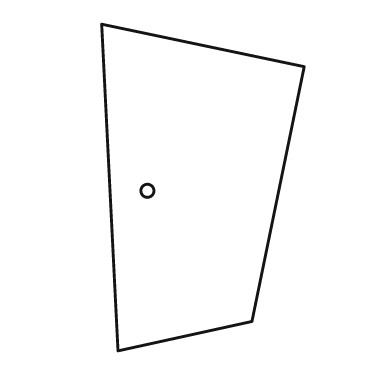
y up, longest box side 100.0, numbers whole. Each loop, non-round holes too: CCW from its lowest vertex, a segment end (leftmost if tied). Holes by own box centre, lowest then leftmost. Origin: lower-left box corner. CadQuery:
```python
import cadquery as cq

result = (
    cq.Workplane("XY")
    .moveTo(5.0, 0.0)
    .lineTo(46.0, 9.0)
    .lineTo(62.0, 87.0)
    .lineTo(0.0, 100.0)
    .close()
    .moveTo(14.0, 49.0)
    .circle(2.0)
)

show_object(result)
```